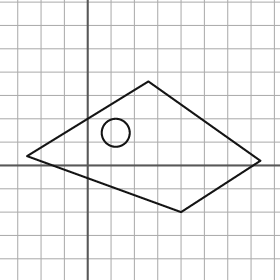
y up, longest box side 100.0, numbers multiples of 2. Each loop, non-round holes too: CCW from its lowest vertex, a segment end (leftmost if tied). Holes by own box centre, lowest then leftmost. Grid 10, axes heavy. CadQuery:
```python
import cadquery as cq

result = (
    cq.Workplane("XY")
    .moveTo(40.0, -20.0)
    .lineTo(74.0, 2.0)
    .lineTo(26.0, 36.0)
    .lineTo(-26.0, 4.0)
    .close()
    .moveTo(12.0, 14.0)
    .circle(6.0)
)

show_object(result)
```